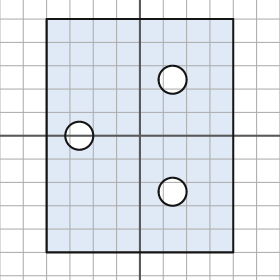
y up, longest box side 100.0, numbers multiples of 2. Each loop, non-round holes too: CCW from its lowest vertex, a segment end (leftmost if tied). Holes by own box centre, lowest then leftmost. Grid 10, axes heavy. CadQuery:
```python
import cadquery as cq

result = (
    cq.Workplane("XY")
    .moveTo(-40.0, -50.0)
    .lineTo(40.0, -50.0)
    .lineTo(40.0, 50.0)
    .lineTo(-40.0, 50.0)
    .close()
    .moveTo(14.0, -24.0)
    .circle(6.0)
    .moveTo(-26.0, 0.0)
    .circle(6.0)
    .moveTo(14.0, 24.0)
    .circle(6.0)
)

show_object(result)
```